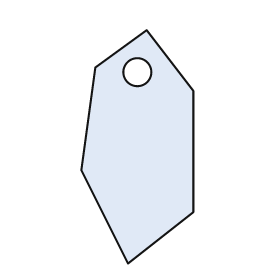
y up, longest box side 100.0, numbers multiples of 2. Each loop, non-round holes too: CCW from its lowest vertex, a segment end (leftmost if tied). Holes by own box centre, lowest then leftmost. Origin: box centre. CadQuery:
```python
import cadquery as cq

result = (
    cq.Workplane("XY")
    .moveTo(-4.0, -50.0)
    .lineTo(24.0, -28.0)
    .lineTo(24.0, 24.0)
    .lineTo(4.0, 50.0)
    .lineTo(-18.0, 34.0)
    .lineTo(-24.0, -10.0)
    .close()
    .moveTo(0.0, 32.0)
    .circle(6.0)
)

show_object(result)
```